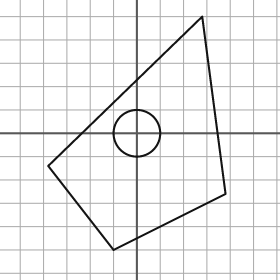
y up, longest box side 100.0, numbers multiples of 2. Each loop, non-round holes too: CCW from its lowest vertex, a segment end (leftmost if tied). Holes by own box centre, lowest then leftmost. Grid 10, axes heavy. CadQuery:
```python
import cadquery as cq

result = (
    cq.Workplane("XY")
    .moveTo(-10.0, -50.0)
    .lineTo(38.0, -26.0)
    .lineTo(28.0, 50.0)
    .lineTo(-38.0, -14.0)
    .close()
    .moveTo(0.0, 0.0)
    .circle(10.0)
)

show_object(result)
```